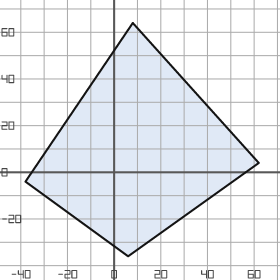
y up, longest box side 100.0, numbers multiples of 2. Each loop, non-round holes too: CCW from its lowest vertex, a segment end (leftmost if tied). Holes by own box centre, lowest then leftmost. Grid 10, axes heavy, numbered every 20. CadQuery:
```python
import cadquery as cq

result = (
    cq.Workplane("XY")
    .moveTo(6.0, -36.0)
    .lineTo(62.0, 4.0)
    .lineTo(8.0, 64.0)
    .lineTo(-38.0, -4.0)
    .close()
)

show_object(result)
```